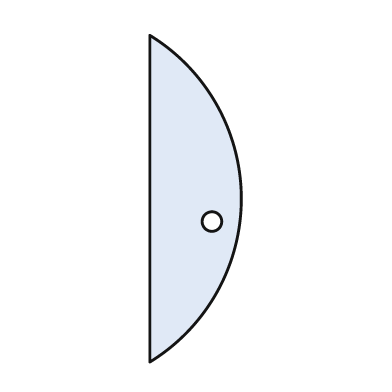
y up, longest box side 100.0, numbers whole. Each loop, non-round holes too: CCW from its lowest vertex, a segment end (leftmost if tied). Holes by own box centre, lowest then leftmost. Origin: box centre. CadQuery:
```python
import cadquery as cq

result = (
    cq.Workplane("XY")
    .moveTo(-14.0, -50.0)
    .threePointArc((14.0, 0.0), (-14.0, 50.0))
    .close()
    .moveTo(5.0, -7.0)
    .circle(3.0)
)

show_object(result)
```